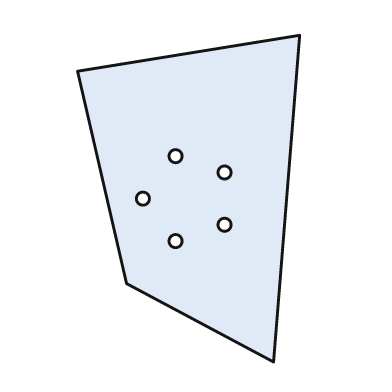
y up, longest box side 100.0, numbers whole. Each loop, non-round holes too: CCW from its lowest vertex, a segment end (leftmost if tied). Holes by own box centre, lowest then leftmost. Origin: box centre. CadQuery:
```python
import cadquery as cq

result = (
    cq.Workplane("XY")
    .moveTo(26.0, -50.0)
    .lineTo(34.0, 50.0)
    .lineTo(-34.0, 39.0)
    .lineTo(-19.0, -26.0)
    .close()
    .moveTo(-4.0, -13.0)
    .circle(2.0)
    .moveTo(11.0, -8.0)
    .circle(2.0)
    .moveTo(-14.0, 0.0)
    .circle(2.0)
    .moveTo(11.0, 8.0)
    .circle(2.0)
    .moveTo(-4.0, 13.0)
    .circle(2.0)
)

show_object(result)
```